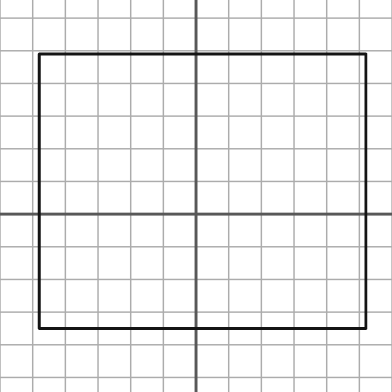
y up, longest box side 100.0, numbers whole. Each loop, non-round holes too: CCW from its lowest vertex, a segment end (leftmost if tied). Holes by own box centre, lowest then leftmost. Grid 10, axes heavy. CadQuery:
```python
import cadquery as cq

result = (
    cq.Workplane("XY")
    .moveTo(-48.0, -35.0)
    .lineTo(52.0, -35.0)
    .lineTo(52.0, 49.0)
    .lineTo(-48.0, 49.0)
    .close()
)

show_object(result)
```